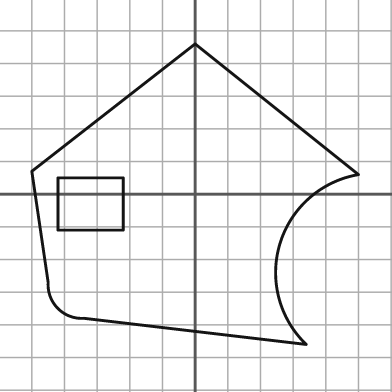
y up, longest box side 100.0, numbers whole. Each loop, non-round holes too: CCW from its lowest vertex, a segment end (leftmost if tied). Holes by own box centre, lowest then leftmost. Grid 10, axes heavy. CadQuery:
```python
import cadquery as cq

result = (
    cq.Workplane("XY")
    .moveTo(34.0, -46.0)
    .threePointArc((26.0, -15.0), (50.0, 6.0))
    .lineTo(0.0, 46.0)
    .lineTo(-50.0, 7.0)
    .lineTo(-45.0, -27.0)
    .threePointArc((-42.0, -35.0), (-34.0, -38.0))
    .close()
    .moveTo(-42.0, -11.0)
    .lineTo(-22.0, -11.0)
    .lineTo(-22.0, 5.0)
    .lineTo(-42.0, 5.0)
    .close()
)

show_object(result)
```